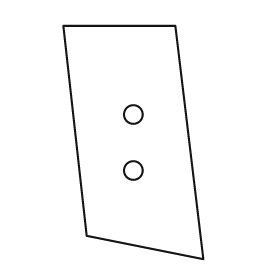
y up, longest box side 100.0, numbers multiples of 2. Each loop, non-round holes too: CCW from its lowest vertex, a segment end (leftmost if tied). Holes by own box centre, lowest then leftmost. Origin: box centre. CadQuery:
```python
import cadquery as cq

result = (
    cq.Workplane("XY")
    .moveTo(30.0, -50.0)
    .lineTo(18.0, 50.0)
    .lineTo(-30.0, 50.0)
    .lineTo(-20.0, -40.0)
    .close()
    .moveTo(0.0, -12.0)
    .circle(4.0)
    .moveTo(0.0, 12.0)
    .circle(4.0)
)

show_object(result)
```